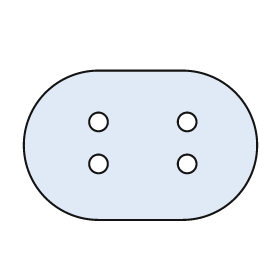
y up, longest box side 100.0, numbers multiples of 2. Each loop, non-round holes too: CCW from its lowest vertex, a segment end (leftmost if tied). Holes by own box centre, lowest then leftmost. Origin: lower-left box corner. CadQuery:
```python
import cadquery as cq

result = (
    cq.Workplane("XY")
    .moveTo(32.0, 0.0)
    .lineTo(68.0, 0.0)
    .threePointArc((100.0, 32.0), (68.0, 64.0))
    .lineTo(32.0, 64.0)
    .threePointArc((0.0, 32.0), (32.0, 0.0))
    .close()
    .moveTo(32.0, 24.0)
    .circle(4.0)
    .moveTo(70.0, 24.0)
    .circle(4.0)
    .moveTo(32.0, 42.0)
    .circle(4.0)
    .moveTo(70.0, 42.0)
    .circle(4.0)
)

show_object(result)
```